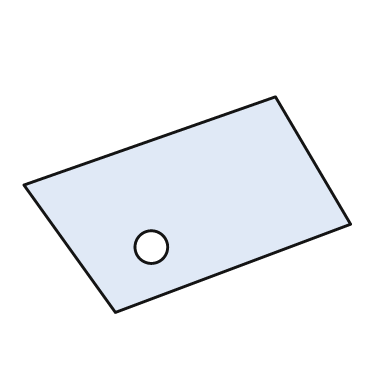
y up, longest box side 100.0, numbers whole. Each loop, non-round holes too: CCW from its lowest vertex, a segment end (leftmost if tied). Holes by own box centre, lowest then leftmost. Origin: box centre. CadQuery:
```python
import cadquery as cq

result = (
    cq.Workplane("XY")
    .moveTo(-22.0, -33.0)
    .lineTo(50.0, -6.0)
    .lineTo(27.0, 33.0)
    .lineTo(-50.0, 6.0)
    .close()
    .moveTo(-11.0, -13.0)
    .circle(5.0)
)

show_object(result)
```